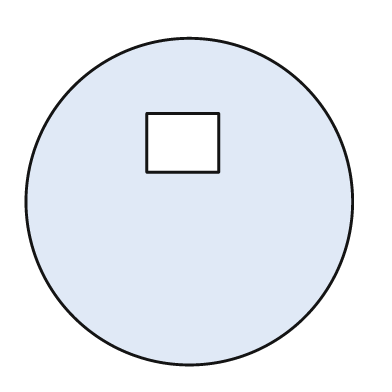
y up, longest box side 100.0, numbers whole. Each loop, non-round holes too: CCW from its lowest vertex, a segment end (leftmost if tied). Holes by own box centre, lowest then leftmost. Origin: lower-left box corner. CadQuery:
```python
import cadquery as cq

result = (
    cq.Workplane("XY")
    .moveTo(50.0, 50.0)
    .circle(50.0)
    .moveTo(37.0, 59.0)
    .lineTo(59.0, 59.0)
    .lineTo(59.0, 77.0)
    .lineTo(37.0, 77.0)
    .close()
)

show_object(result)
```